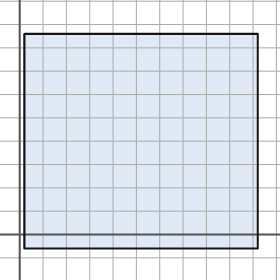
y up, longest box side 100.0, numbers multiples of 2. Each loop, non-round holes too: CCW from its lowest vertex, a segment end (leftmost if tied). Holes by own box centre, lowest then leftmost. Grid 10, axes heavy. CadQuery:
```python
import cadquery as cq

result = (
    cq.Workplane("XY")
    .moveTo(2.0, -6.0)
    .lineTo(102.0, -6.0)
    .lineTo(102.0, 86.0)
    .lineTo(2.0, 86.0)
    .close()
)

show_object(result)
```